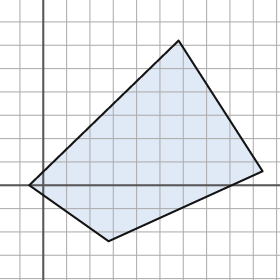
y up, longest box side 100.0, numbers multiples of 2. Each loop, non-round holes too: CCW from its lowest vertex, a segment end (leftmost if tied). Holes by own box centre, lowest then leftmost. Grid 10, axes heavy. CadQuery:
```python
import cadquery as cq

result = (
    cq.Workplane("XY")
    .moveTo(28.0, -24.0)
    .lineTo(94.0, 6.0)
    .lineTo(58.0, 62.0)
    .lineTo(-6.0, 0.0)
    .close()
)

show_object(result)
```